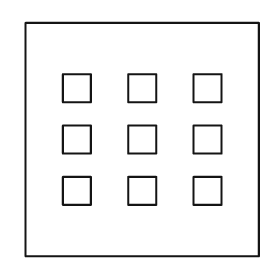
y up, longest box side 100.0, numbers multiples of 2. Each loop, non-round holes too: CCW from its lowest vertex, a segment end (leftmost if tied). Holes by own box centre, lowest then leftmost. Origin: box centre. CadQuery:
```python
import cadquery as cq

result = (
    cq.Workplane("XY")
    .moveTo(-50.0, -50.0)
    .lineTo(50.0, -50.0)
    .lineTo(50.0, 50.0)
    .lineTo(-50.0, 50.0)
    .close()
    .moveTo(-34.0, -28.0)
    .lineTo(-22.0, -28.0)
    .lineTo(-22.0, -16.0)
    .lineTo(-34.0, -16.0)
    .close()
    .moveTo(-6.0, -28.0)
    .lineTo(6.0, -28.0)
    .lineTo(6.0, -16.0)
    .lineTo(-6.0, -16.0)
    .close()
    .moveTo(22.0, -28.0)
    .lineTo(34.0, -28.0)
    .lineTo(34.0, -16.0)
    .lineTo(22.0, -16.0)
    .close()
    .moveTo(-34.0, -6.0)
    .lineTo(-22.0, -6.0)
    .lineTo(-22.0, 6.0)
    .lineTo(-34.0, 6.0)
    .close()
    .moveTo(-6.0, -6.0)
    .lineTo(6.0, -6.0)
    .lineTo(6.0, 6.0)
    .lineTo(-6.0, 6.0)
    .close()
    .moveTo(22.0, -6.0)
    .lineTo(34.0, -6.0)
    .lineTo(34.0, 6.0)
    .lineTo(22.0, 6.0)
    .close()
    .moveTo(-34.0, 16.0)
    .lineTo(-22.0, 16.0)
    .lineTo(-22.0, 28.0)
    .lineTo(-34.0, 28.0)
    .close()
    .moveTo(-6.0, 16.0)
    .lineTo(6.0, 16.0)
    .lineTo(6.0, 28.0)
    .lineTo(-6.0, 28.0)
    .close()
    .moveTo(22.0, 16.0)
    .lineTo(34.0, 16.0)
    .lineTo(34.0, 28.0)
    .lineTo(22.0, 28.0)
    .close()
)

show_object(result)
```